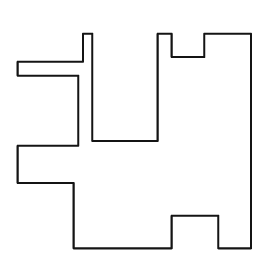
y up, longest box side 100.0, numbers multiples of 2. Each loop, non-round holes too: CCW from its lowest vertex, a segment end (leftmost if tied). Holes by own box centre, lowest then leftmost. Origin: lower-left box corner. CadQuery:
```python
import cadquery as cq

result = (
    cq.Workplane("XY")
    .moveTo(24.0, 0.0)
    .lineTo(66.0, 0.0)
    .lineTo(66.0, 14.0)
    .lineTo(86.0, 14.0)
    .lineTo(86.0, 0.0)
    .lineTo(100.0, 0.0)
    .lineTo(100.0, 92.0)
    .lineTo(80.0, 92.0)
    .lineTo(80.0, 82.0)
    .lineTo(66.0, 82.0)
    .lineTo(66.0, 92.0)
    .lineTo(60.0, 92.0)
    .lineTo(60.0, 46.0)
    .lineTo(32.0, 46.0)
    .lineTo(32.0, 92.0)
    .lineTo(28.0, 92.0)
    .lineTo(28.0, 80.0)
    .lineTo(0.0, 80.0)
    .lineTo(0.0, 74.0)
    .lineTo(26.0, 74.0)
    .lineTo(26.0, 44.0)
    .lineTo(0.0, 44.0)
    .lineTo(0.0, 28.0)
    .lineTo(24.0, 28.0)
    .close()
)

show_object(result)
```